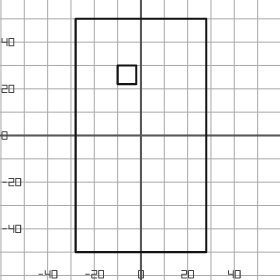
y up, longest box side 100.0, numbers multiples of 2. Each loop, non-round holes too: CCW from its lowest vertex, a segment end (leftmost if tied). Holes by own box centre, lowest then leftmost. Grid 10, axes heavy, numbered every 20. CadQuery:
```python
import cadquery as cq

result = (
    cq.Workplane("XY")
    .moveTo(-28.0, -50.0)
    .lineTo(28.0, -50.0)
    .lineTo(28.0, 50.0)
    .lineTo(-28.0, 50.0)
    .close()
    .moveTo(-10.0, 22.0)
    .lineTo(-2.0, 22.0)
    .lineTo(-2.0, 30.0)
    .lineTo(-10.0, 30.0)
    .close()
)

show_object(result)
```